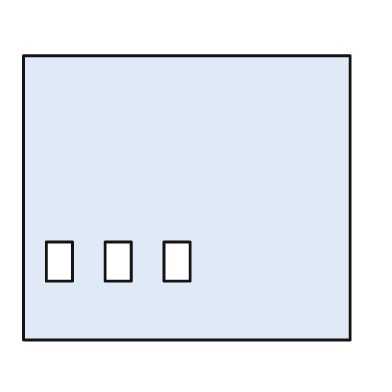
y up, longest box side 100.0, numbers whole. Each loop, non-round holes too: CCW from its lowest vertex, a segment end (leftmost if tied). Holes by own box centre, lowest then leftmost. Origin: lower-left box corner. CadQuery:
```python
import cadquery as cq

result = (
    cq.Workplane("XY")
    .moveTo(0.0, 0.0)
    .lineTo(100.0, 0.0)
    .lineTo(100.0, 87.0)
    .lineTo(0.0, 87.0)
    .close()
    .moveTo(7.0, 18.0)
    .lineTo(15.0, 18.0)
    .lineTo(15.0, 30.0)
    .lineTo(7.0, 30.0)
    .close()
    .moveTo(25.0, 18.0)
    .lineTo(33.0, 18.0)
    .lineTo(33.0, 30.0)
    .lineTo(25.0, 30.0)
    .close()
    .moveTo(43.0, 18.0)
    .lineTo(51.0, 18.0)
    .lineTo(51.0, 30.0)
    .lineTo(43.0, 30.0)
    .close()
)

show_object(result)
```